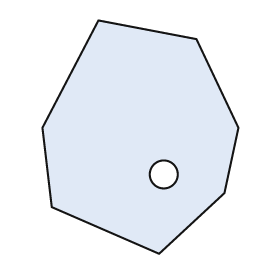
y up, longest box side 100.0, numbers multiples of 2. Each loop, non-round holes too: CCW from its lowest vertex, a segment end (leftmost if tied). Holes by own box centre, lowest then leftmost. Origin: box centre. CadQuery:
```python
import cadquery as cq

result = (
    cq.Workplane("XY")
    .moveTo(8.0, -50.0)
    .lineTo(36.0, -24.0)
    .lineTo(42.0, 4.0)
    .lineTo(24.0, 42.0)
    .lineTo(-18.0, 50.0)
    .lineTo(-42.0, 4.0)
    .lineTo(-38.0, -30.0)
    .close()
    .moveTo(10.0, -16.0)
    .circle(6.0)
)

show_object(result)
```